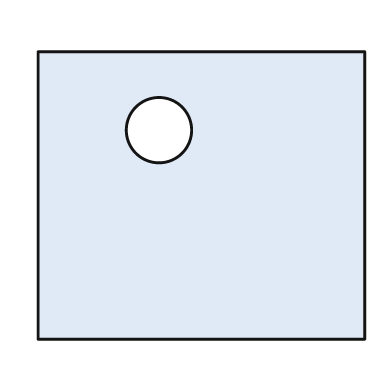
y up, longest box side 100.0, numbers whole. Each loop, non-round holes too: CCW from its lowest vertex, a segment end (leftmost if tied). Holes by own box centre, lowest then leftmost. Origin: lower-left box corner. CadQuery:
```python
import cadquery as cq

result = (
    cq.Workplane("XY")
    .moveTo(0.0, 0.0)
    .lineTo(100.0, 0.0)
    .lineTo(100.0, 88.0)
    .lineTo(0.0, 88.0)
    .close()
    .moveTo(37.0, 64.0)
    .circle(10.0)
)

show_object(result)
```